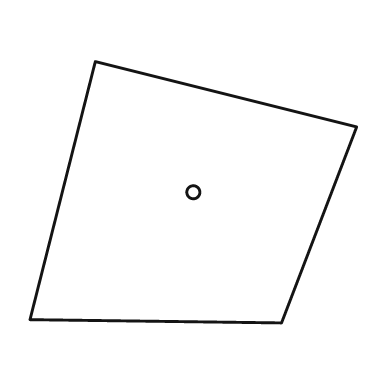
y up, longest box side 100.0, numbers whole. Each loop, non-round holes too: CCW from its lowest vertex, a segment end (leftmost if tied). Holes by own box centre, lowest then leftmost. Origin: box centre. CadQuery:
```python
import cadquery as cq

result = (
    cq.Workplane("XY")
    .moveTo(27.0, -40.0)
    .lineTo(50.0, 20.0)
    .lineTo(-30.0, 40.0)
    .lineTo(-50.0, -39.0)
    .close()
    .moveTo(0.0, 0.0)
    .circle(2.0)
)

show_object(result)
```